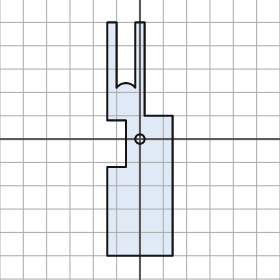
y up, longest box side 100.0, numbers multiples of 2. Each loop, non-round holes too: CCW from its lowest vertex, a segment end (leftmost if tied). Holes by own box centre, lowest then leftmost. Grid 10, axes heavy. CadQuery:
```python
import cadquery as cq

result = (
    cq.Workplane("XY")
    .moveTo(-14.0, -50.0)
    .lineTo(14.0, -50.0)
    .lineTo(14.0, 10.0)
    .lineTo(2.0, 10.0)
    .lineTo(2.0, 50.0)
    .lineTo(-2.0, 50.0)
    .lineTo(-2.0, 22.0)
    .threePointArc((-6.0, 24.0), (-10.0, 22.0))
    .lineTo(-10.0, 50.0)
    .lineTo(-14.0, 50.0)
    .lineTo(-14.0, 8.0)
    .lineTo(-6.0, 8.0)
    .lineTo(-6.0, -12.0)
    .lineTo(-14.0, -12.0)
    .close()
    .moveTo(0.0, 0.0)
    .circle(2.0)
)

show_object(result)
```